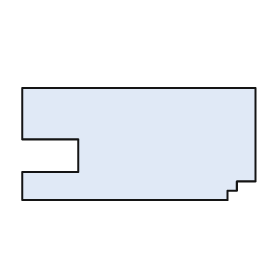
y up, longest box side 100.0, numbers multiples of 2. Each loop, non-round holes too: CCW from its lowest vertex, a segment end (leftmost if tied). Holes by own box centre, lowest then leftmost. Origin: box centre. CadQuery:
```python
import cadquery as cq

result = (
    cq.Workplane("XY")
    .moveTo(-50.0, -24.0)
    .lineTo(38.0, -24.0)
    .lineTo(38.0, -20.0)
    .lineTo(42.0, -20.0)
    .lineTo(42.0, -16.0)
    .lineTo(50.0, -16.0)
    .lineTo(50.0, 24.0)
    .lineTo(-50.0, 24.0)
    .lineTo(-50.0, 2.0)
    .lineTo(-26.0, 2.0)
    .lineTo(-26.0, -12.0)
    .lineTo(-50.0, -12.0)
    .close()
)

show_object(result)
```